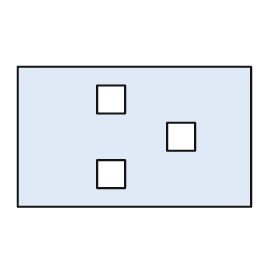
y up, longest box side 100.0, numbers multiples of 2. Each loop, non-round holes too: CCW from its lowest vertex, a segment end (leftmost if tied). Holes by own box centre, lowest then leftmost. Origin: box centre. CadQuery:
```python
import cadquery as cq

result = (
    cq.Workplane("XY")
    .moveTo(-50.0, -30.0)
    .lineTo(50.0, -30.0)
    .lineTo(50.0, 30.0)
    .lineTo(-50.0, 30.0)
    .close()
    .moveTo(-16.0, -22.0)
    .lineTo(-4.0, -22.0)
    .lineTo(-4.0, -10.0)
    .lineTo(-16.0, -10.0)
    .close()
    .moveTo(14.0, -6.0)
    .lineTo(26.0, -6.0)
    .lineTo(26.0, 6.0)
    .lineTo(14.0, 6.0)
    .close()
    .moveTo(-16.0, 10.0)
    .lineTo(-4.0, 10.0)
    .lineTo(-4.0, 22.0)
    .lineTo(-16.0, 22.0)
    .close()
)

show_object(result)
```